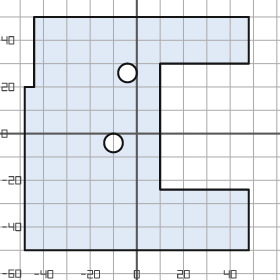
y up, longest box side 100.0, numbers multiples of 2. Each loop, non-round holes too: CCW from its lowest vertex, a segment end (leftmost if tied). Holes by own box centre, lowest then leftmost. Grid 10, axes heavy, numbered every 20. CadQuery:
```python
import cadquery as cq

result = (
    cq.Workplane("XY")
    .moveTo(-48.0, -50.0)
    .lineTo(48.0, -50.0)
    .lineTo(48.0, -24.0)
    .lineTo(10.0, -24.0)
    .lineTo(10.0, 30.0)
    .lineTo(48.0, 30.0)
    .lineTo(48.0, 50.0)
    .lineTo(-44.0, 50.0)
    .lineTo(-44.0, 20.0)
    .lineTo(-48.0, 20.0)
    .close()
    .moveTo(-10.0, -4.0)
    .circle(4.0)
    .moveTo(-4.0, 26.0)
    .circle(4.0)
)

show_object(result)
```